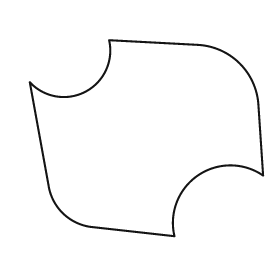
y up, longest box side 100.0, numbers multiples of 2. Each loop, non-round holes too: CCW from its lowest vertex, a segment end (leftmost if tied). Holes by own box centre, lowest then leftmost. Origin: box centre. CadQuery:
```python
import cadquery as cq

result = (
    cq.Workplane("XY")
    .moveTo(12.0, -42.0)
    .threePointArc((22.0, -16.0), (50.0, -16.0))
    .lineTo(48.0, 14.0)
    .threePointArc((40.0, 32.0), (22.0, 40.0))
    .lineTo(-16.0, 42.0)
    .threePointArc((-26.0, 20.0), (-50.0, 24.0))
    .lineTo(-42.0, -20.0)
    .threePointArc((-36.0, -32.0), (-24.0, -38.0))
    .close()
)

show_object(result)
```